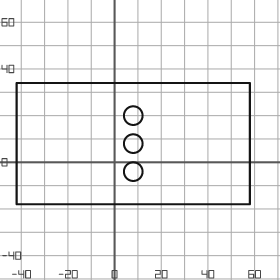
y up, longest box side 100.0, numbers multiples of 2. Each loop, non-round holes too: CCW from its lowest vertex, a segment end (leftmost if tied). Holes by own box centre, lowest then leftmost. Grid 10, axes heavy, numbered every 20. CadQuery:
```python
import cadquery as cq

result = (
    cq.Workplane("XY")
    .moveTo(-42.0, -18.0)
    .lineTo(58.0, -18.0)
    .lineTo(58.0, 34.0)
    .lineTo(-42.0, 34.0)
    .close()
    .moveTo(8.0, -4.0)
    .circle(4.0)
    .moveTo(8.0, 8.0)
    .circle(4.0)
    .moveTo(8.0, 20.0)
    .circle(4.0)
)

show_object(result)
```